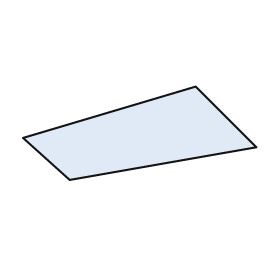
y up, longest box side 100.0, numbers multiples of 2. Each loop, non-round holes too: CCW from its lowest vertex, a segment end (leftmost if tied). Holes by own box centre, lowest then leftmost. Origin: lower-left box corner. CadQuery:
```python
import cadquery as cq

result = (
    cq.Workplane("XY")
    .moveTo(20.0, 0.0)
    .lineTo(100.0, 14.0)
    .lineTo(74.0, 40.0)
    .lineTo(0.0, 18.0)
    .close()
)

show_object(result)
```